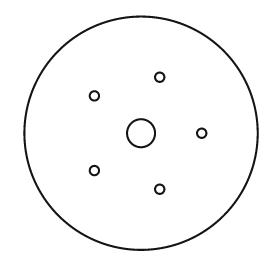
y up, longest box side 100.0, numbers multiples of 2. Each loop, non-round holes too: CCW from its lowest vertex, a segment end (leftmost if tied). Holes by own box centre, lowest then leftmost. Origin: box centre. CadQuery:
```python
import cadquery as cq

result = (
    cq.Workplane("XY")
    .moveTo(0.0, 0.0)
    .circle(50.0)
    .moveTo(8.0, -24.0)
    .circle(2.0)
    .moveTo(-20.0, -16.0)
    .circle(2.0)
    .moveTo(0.0, 0.0)
    .circle(6.0)
    .moveTo(26.0, 0.0)
    .circle(2.0)
    .moveTo(-20.0, 16.0)
    .circle(2.0)
    .moveTo(8.0, 24.0)
    .circle(2.0)
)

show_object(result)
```